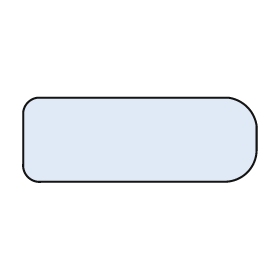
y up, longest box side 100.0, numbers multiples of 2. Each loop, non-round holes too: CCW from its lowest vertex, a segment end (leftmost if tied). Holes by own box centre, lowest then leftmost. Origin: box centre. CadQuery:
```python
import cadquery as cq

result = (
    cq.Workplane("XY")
    .moveTo(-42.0, -18.0)
    .lineTo(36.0, -18.0)
    .threePointArc((46.0, -14.0), (50.0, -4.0))
    .lineTo(50.0, 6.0)
    .threePointArc((46.0, 14.0), (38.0, 18.0))
    .lineTo(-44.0, 18.0)
    .threePointArc((-48.0, 16.0), (-50.0, 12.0))
    .lineTo(-50.0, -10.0)
    .threePointArc((-48.0, -16.0), (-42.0, -18.0))
    .close()
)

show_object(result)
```